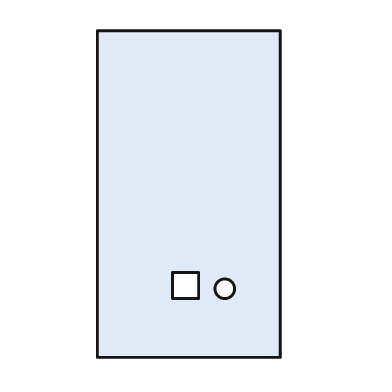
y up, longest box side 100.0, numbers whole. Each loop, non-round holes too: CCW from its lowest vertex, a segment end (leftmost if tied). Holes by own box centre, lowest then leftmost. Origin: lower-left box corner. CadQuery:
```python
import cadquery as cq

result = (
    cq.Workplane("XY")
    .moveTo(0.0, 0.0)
    .lineTo(56.0, 0.0)
    .lineTo(56.0, 100.0)
    .lineTo(0.0, 100.0)
    .close()
    .moveTo(39.0, 21.0)
    .circle(3.0)
    .moveTo(23.0, 18.0)
    .lineTo(31.0, 18.0)
    .lineTo(31.0, 26.0)
    .lineTo(23.0, 26.0)
    .close()
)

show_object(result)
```